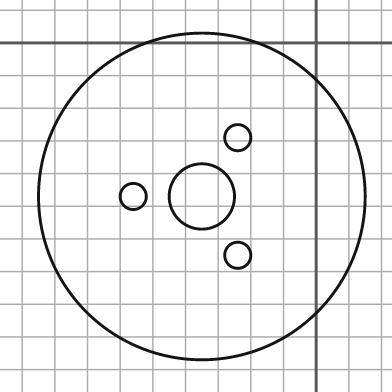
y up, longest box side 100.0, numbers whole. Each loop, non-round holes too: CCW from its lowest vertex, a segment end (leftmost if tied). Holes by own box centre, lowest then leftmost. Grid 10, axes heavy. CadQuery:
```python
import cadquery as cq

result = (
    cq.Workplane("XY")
    .moveTo(-35.0, -47.0)
    .circle(50.0)
    .moveTo(-24.0, -65.0)
    .circle(4.0)
    .moveTo(-56.0, -47.0)
    .circle(4.0)
    .moveTo(-35.0, -47.0)
    .circle(10.0)
    .moveTo(-24.0, -29.0)
    .circle(4.0)
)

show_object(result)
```